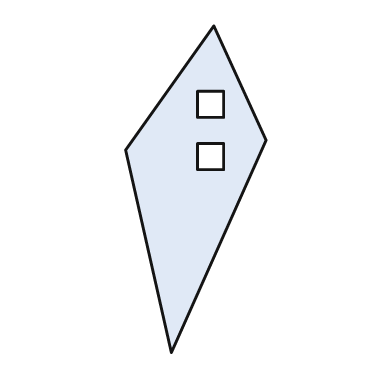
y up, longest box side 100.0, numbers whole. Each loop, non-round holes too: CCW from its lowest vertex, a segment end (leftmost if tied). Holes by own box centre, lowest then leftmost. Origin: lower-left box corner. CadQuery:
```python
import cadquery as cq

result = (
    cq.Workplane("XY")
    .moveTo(14.0, 0.0)
    .lineTo(43.0, 65.0)
    .lineTo(27.0, 100.0)
    .lineTo(0.0, 62.0)
    .close()
    .moveTo(22.0, 56.0)
    .lineTo(30.0, 56.0)
    .lineTo(30.0, 64.0)
    .lineTo(22.0, 64.0)
    .close()
    .moveTo(22.0, 72.0)
    .lineTo(30.0, 72.0)
    .lineTo(30.0, 80.0)
    .lineTo(22.0, 80.0)
    .close()
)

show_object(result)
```